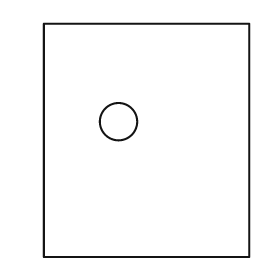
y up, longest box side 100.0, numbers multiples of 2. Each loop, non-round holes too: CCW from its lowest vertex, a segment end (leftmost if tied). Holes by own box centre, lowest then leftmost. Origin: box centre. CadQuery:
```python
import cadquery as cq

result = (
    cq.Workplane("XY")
    .moveTo(-44.0, -50.0)
    .lineTo(44.0, -50.0)
    .lineTo(44.0, 50.0)
    .lineTo(-44.0, 50.0)
    .close()
    .moveTo(-12.0, 8.0)
    .circle(8.0)
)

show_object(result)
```